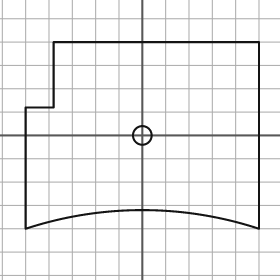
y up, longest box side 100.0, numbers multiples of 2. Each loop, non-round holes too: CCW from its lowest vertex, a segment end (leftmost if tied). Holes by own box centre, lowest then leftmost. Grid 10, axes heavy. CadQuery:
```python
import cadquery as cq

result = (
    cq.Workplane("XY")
    .moveTo(-50.0, -40.0)
    .threePointArc((0.0, -32.0), (50.0, -40.0))
    .lineTo(50.0, 40.0)
    .lineTo(-38.0, 40.0)
    .lineTo(-38.0, 12.0)
    .lineTo(-50.0, 12.0)
    .close()
    .moveTo(0.0, 0.0)
    .circle(4.0)
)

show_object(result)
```